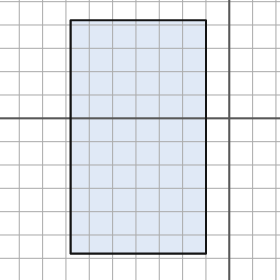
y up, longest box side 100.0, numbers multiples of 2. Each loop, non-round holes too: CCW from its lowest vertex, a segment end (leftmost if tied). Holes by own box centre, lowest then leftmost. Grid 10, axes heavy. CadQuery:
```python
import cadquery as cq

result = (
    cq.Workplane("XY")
    .moveTo(-68.0, -58.0)
    .lineTo(-10.0, -58.0)
    .lineTo(-10.0, 42.0)
    .lineTo(-68.0, 42.0)
    .close()
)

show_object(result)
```